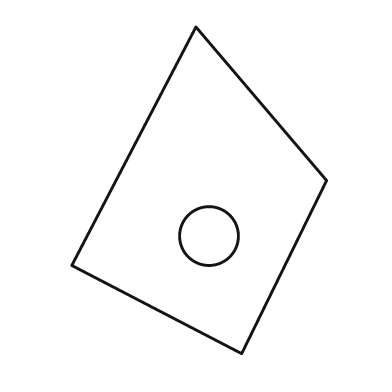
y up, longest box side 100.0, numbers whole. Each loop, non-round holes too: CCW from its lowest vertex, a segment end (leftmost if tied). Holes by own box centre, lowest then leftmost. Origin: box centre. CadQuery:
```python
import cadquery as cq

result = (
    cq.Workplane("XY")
    .moveTo(13.0, -50.0)
    .lineTo(39.0, 3.0)
    .lineTo(-1.0, 50.0)
    .lineTo(-39.0, -23.0)
    .close()
    .moveTo(3.0, -14.0)
    .circle(9.0)
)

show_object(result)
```